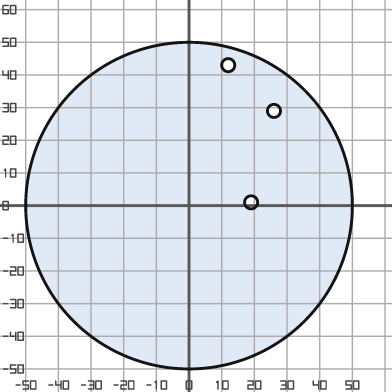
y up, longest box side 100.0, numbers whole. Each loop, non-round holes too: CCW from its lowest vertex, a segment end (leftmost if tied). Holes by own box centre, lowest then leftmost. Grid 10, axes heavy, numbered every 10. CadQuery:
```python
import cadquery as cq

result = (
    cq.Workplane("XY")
    .moveTo(0.0, 0.0)
    .circle(50.0)
    .moveTo(19.0, 1.0)
    .circle(2.0)
    .moveTo(26.0, 29.0)
    .circle(2.0)
    .moveTo(12.0, 43.0)
    .circle(2.0)
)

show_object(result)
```